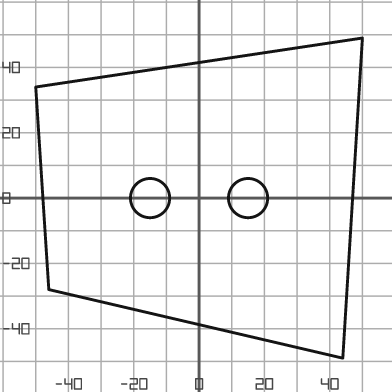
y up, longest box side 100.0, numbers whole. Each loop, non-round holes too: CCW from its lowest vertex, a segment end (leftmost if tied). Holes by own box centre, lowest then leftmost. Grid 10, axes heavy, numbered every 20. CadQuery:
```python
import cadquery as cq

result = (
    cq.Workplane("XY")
    .moveTo(44.0, -49.0)
    .lineTo(50.0, 49.0)
    .lineTo(-50.0, 34.0)
    .lineTo(-46.0, -28.0)
    .close()
    .moveTo(-15.0, 0.0)
    .circle(6.0)
    .moveTo(15.0, 0.0)
    .circle(6.0)
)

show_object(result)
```